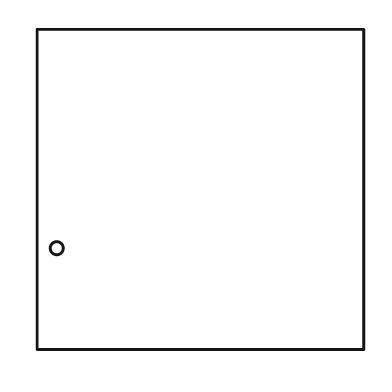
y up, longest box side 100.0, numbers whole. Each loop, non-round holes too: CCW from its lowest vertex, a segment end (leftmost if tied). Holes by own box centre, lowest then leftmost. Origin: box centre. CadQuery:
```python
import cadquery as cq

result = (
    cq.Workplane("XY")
    .moveTo(-50.0, -49.0)
    .lineTo(50.0, -49.0)
    .lineTo(50.0, 49.0)
    .lineTo(-50.0, 49.0)
    .close()
    .moveTo(-44.0, -18.0)
    .circle(2.0)
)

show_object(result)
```